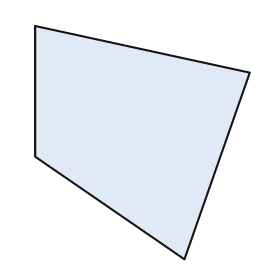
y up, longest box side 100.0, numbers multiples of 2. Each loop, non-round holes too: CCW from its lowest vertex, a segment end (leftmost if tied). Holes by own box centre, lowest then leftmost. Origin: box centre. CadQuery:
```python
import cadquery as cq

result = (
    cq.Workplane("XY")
    .moveTo(18.0, -50.0)
    .lineTo(46.0, 30.0)
    .lineTo(-46.0, 50.0)
    .lineTo(-46.0, -6.0)
    .close()
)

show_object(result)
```